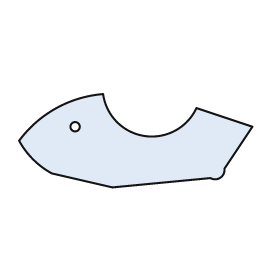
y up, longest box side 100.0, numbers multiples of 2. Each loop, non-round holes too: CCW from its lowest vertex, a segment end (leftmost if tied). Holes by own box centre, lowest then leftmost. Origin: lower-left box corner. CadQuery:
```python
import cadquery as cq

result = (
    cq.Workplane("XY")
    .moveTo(40.0, 0.0)
    .lineTo(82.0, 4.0)
    .threePointArc((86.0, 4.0), (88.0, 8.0))
    .lineTo(100.0, 26.0)
    .lineTo(76.0, 34.0)
    .threePointArc((54.0, 22.0), (36.0, 40.0))
    .threePointArc((16.0, 34.0), (0.0, 20.0))
    .threePointArc((6.0, 12.0), (14.0, 6.0))
    .close()
    .moveTo(24.0, 26.0)
    .circle(2.0)
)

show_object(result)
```